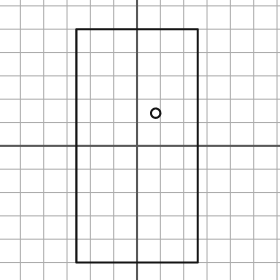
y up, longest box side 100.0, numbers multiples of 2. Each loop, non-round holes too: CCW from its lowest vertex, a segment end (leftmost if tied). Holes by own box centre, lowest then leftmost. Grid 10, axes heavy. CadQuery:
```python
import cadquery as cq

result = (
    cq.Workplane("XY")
    .moveTo(-26.0, -50.0)
    .lineTo(26.0, -50.0)
    .lineTo(26.0, 50.0)
    .lineTo(-26.0, 50.0)
    .close()
    .moveTo(8.0, 14.0)
    .circle(2.0)
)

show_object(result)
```